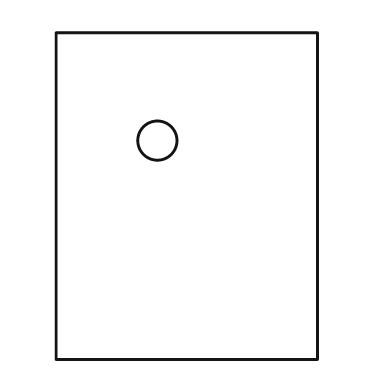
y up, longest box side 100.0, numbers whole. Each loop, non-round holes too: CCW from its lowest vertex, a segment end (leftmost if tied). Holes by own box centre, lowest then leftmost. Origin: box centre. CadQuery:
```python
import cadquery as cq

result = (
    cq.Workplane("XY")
    .moveTo(-40.0, -50.0)
    .lineTo(40.0, -50.0)
    .lineTo(40.0, 50.0)
    .lineTo(-40.0, 50.0)
    .close()
    .moveTo(-9.0, 17.0)
    .circle(6.0)
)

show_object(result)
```